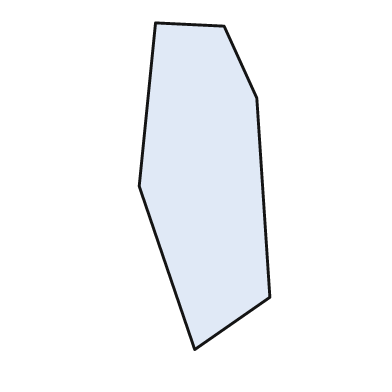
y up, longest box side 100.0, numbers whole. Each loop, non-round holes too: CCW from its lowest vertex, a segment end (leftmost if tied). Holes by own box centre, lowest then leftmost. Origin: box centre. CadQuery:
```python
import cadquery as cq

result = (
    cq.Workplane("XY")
    .moveTo(-3.0, -50.0)
    .lineTo(20.0, -34.0)
    .lineTo(16.0, 27.0)
    .lineTo(6.0, 49.0)
    .lineTo(-15.0, 50.0)
    .lineTo(-20.0, 0.0)
    .close()
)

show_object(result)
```